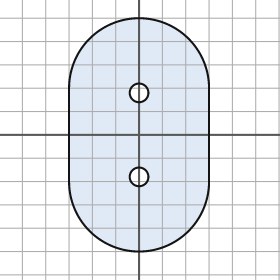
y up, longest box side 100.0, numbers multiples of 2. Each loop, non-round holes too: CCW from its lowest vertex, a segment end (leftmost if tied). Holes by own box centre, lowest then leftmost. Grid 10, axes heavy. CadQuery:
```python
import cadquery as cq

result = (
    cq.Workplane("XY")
    .moveTo(-30.0, -20.0)
    .threePointArc((0.0, -50.0), (30.0, -20.0))
    .lineTo(30.0, 20.0)
    .threePointArc((0.0, 50.0), (-30.0, 20.0))
    .close()
    .moveTo(0.0, -18.0)
    .circle(4.0)
    .moveTo(0.0, 18.0)
    .circle(4.0)
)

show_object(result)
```